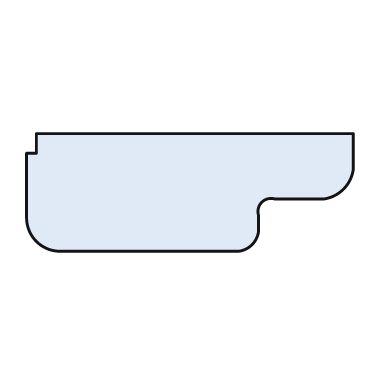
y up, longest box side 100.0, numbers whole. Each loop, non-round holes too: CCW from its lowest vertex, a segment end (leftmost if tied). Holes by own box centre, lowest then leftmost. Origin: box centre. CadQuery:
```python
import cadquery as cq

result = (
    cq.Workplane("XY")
    .moveTo(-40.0, -18.0)
    .lineTo(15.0, -18.0)
    .threePointArc((19.0, -16.0), (21.0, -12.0))
    .lineTo(21.0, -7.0)
    .threePointArc((22.0, -3.0), (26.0, -2.0))
    .lineTo(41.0, -2.0)
    .threePointArc((47.0, 1.0), (50.0, 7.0))
    .lineTo(50.0, 18.0)
    .lineTo(-47.0, 18.0)
    .lineTo(-47.0, 12.0)
    .lineTo(-50.0, 12.0)
    .lineTo(-50.0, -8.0)
    .threePointArc((-47.0, -15.0), (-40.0, -18.0))
    .close()
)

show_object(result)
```